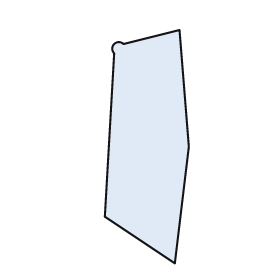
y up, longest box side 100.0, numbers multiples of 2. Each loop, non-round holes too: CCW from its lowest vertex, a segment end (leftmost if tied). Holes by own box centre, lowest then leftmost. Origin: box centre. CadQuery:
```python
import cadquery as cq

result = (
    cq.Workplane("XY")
    .moveTo(12.0, -50.0)
    .lineTo(18.0, 0.0)
    .lineTo(14.0, 50.0)
    .lineTo(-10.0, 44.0)
    .threePointArc((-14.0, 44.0), (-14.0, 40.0))
    .lineTo(-18.0, -30.0)
    .close()
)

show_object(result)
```